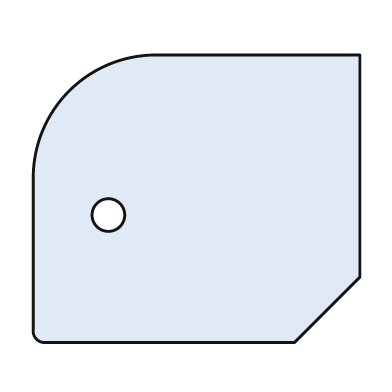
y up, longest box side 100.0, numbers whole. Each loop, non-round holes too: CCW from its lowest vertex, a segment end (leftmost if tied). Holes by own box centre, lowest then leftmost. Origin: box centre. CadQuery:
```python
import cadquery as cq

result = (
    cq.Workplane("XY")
    .moveTo(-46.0, -44.0)
    .lineTo(30.0, -44.0)
    .lineTo(50.0, -24.0)
    .lineTo(50.0, 44.0)
    .lineTo(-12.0, 44.0)
    .threePointArc((-39.0, 33.0), (-50.0, 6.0))
    .lineTo(-50.0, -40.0)
    .threePointArc((-49.0, -43.0), (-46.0, -44.0))
    .close()
    .moveTo(-27.0, -5.0)
    .circle(5.0)
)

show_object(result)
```